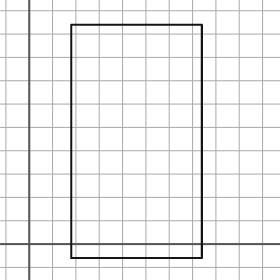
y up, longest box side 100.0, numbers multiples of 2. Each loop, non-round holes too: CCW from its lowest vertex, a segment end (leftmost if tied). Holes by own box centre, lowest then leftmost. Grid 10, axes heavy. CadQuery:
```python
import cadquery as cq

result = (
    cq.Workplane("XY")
    .moveTo(18.0, -6.0)
    .lineTo(74.0, -6.0)
    .lineTo(74.0, 94.0)
    .lineTo(18.0, 94.0)
    .close()
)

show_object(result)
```